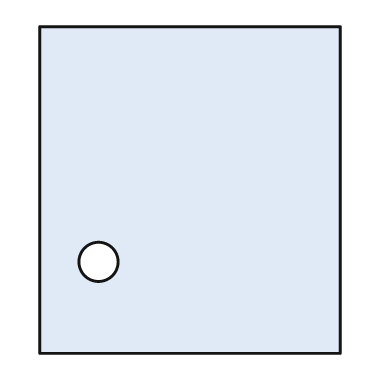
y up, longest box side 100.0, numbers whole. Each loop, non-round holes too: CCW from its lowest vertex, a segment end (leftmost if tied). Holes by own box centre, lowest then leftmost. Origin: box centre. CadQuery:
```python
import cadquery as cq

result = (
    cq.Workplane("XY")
    .moveTo(-46.0, -50.0)
    .lineTo(46.0, -50.0)
    .lineTo(46.0, 50.0)
    .lineTo(-46.0, 50.0)
    .close()
    .moveTo(-28.0, -22.0)
    .circle(6.0)
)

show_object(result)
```